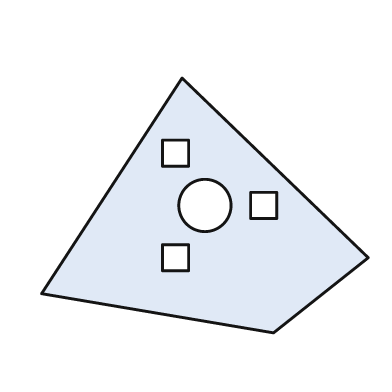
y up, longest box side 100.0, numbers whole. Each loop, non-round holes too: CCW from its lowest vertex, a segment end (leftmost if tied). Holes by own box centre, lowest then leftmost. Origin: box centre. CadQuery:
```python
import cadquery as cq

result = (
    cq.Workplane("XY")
    .moveTo(21.0, -39.0)
    .lineTo(50.0, -16.0)
    .lineTo(-7.0, 39.0)
    .lineTo(-50.0, -27.0)
    .close()
    .moveTo(-13.0, -20.0)
    .lineTo(-5.0, -20.0)
    .lineTo(-5.0, -12.0)
    .lineTo(-13.0, -12.0)
    .close()
    .moveTo(0.0, 0.0)
    .circle(8.0)
    .moveTo(14.0, -4.0)
    .lineTo(22.0, -4.0)
    .lineTo(22.0, 4.0)
    .lineTo(14.0, 4.0)
    .close()
    .moveTo(-13.0, 12.0)
    .lineTo(-5.0, 12.0)
    .lineTo(-5.0, 20.0)
    .lineTo(-13.0, 20.0)
    .close()
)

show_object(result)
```